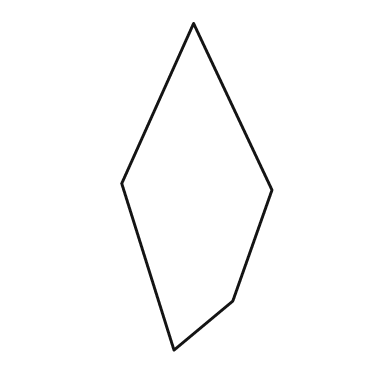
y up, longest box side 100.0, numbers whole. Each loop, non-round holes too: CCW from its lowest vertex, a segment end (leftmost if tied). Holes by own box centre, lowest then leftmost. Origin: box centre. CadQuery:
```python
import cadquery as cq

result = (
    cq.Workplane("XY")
    .moveTo(-7.0, -50.0)
    .lineTo(11.0, -35.0)
    .lineTo(23.0, -1.0)
    .lineTo(-1.0, 50.0)
    .lineTo(-23.0, 1.0)
    .close()
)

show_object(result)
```